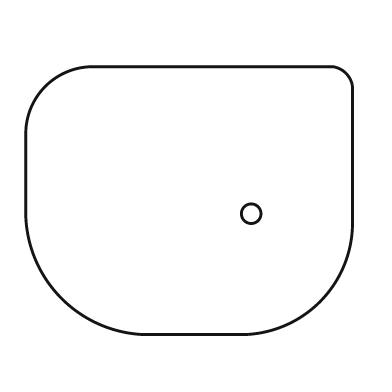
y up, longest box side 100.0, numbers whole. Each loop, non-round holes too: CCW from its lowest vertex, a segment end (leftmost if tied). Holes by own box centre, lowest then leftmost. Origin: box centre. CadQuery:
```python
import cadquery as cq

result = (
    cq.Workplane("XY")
    .moveTo(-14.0, -41.0)
    .lineTo(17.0, -41.0)
    .threePointArc((40.0, -31.0), (50.0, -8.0))
    .lineTo(50.0, 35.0)
    .threePointArc((48.0, 39.0), (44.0, 41.0))
    .lineTo(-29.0, 41.0)
    .threePointArc((-44.0, 35.0), (-50.0, 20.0))
    .lineTo(-50.0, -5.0)
    .threePointArc((-39.0, -30.0), (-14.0, -41.0))
    .close()
    .moveTo(19.0, -4.0)
    .circle(3.0)
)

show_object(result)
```